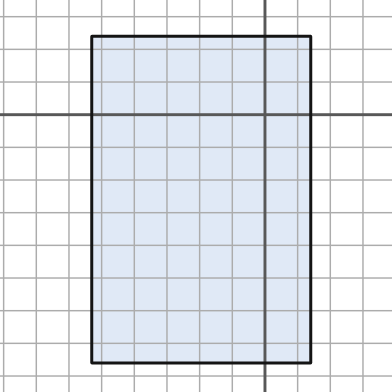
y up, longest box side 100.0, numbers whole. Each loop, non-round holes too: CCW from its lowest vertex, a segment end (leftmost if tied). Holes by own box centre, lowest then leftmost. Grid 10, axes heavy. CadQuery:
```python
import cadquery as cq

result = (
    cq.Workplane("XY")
    .moveTo(-53.0, -76.0)
    .lineTo(14.0, -76.0)
    .lineTo(14.0, 24.0)
    .lineTo(-53.0, 24.0)
    .close()
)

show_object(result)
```